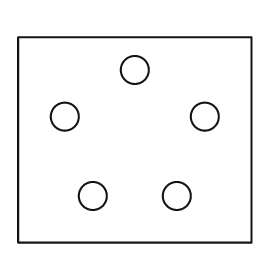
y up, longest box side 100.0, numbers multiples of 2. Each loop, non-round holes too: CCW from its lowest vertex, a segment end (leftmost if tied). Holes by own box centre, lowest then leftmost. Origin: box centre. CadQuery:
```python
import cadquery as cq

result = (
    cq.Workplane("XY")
    .moveTo(-50.0, -44.0)
    .lineTo(50.0, -44.0)
    .lineTo(50.0, 44.0)
    .lineTo(-50.0, 44.0)
    .close()
    .moveTo(-18.0, -24.0)
    .circle(6.0)
    .moveTo(18.0, -24.0)
    .circle(6.0)
    .moveTo(-30.0, 10.0)
    .circle(6.0)
    .moveTo(30.0, 10.0)
    .circle(6.0)
    .moveTo(0.0, 30.0)
    .circle(6.0)
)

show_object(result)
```